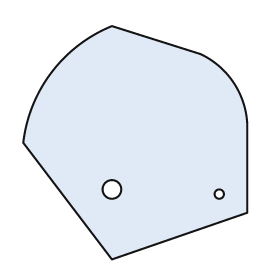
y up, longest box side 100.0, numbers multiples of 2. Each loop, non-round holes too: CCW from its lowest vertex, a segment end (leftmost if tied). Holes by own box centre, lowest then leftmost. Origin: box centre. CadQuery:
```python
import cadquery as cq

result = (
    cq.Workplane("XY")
    .moveTo(-10.0, -50.0)
    .lineTo(48.0, -30.0)
    .lineTo(48.0, 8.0)
    .threePointArc((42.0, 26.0), (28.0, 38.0))
    .lineTo(-10.0, 50.0)
    .threePointArc((-36.0, 30.0), (-48.0, 0.0))
    .close()
    .moveTo(36.0, -22.0)
    .circle(2.0)
    .moveTo(-10.0, -20.0)
    .circle(4.0)
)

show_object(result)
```